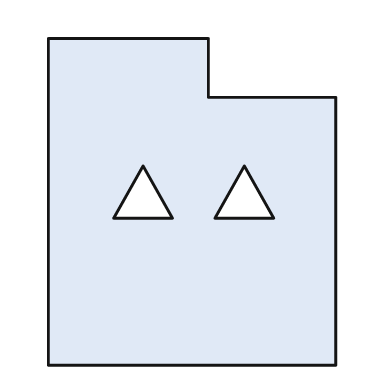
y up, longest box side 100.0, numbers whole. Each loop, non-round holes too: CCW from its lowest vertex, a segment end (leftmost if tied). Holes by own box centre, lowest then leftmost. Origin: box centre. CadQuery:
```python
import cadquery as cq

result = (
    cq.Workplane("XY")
    .moveTo(-44.0, -50.0)
    .lineTo(44.0, -50.0)
    .lineTo(44.0, 32.0)
    .lineTo(5.0, 32.0)
    .lineTo(5.0, 50.0)
    .lineTo(-44.0, 50.0)
    .close()
    .moveTo(-24.0, -5.0)
    .lineTo(-6.0, -5.0)
    .lineTo(-15.0, 11.0)
    .close()
    .moveTo(7.0, -5.0)
    .lineTo(25.0, -5.0)
    .lineTo(16.0, 11.0)
    .close()
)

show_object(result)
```